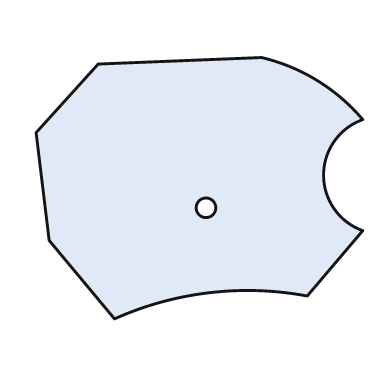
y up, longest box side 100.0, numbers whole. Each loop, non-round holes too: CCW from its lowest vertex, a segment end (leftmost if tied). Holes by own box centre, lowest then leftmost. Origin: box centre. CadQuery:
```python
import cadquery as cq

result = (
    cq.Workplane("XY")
    .moveTo(-26.0, -40.0)
    .threePointArc((3.0, -32.0), (33.0, -33.0))
    .lineTo(50.0, -13.0)
    .threePointArc((38.0, 4.0), (50.0, 21.0))
    .threePointArc((36.0, 33.0), (19.0, 40.0))
    .lineTo(-31.0, 38.0)
    .lineTo(-50.0, 17.0)
    .lineTo(-46.0, -16.0)
    .close()
    .moveTo(2.0, -6.0)
    .circle(3.0)
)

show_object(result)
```